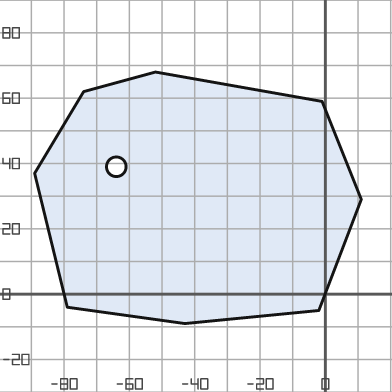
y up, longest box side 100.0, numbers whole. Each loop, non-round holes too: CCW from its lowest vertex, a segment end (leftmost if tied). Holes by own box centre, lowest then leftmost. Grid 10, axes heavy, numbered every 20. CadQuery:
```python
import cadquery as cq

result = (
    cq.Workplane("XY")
    .moveTo(-43.0, -9.0)
    .lineTo(-2.0, -5.0)
    .lineTo(11.0, 29.0)
    .lineTo(-1.0, 59.0)
    .lineTo(-52.0, 68.0)
    .lineTo(-74.0, 62.0)
    .lineTo(-89.0, 37.0)
    .lineTo(-79.0, -4.0)
    .close()
    .moveTo(-64.0, 39.0)
    .circle(3.0)
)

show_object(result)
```